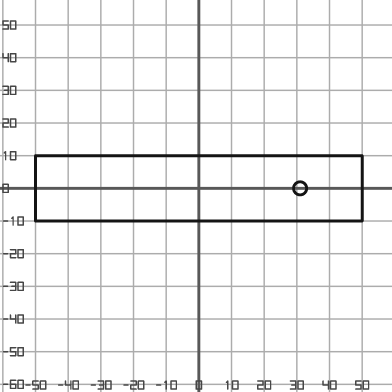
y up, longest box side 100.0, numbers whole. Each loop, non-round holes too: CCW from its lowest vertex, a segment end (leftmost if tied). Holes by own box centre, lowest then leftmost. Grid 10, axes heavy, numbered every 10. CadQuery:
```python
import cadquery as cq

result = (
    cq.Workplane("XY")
    .moveTo(-50.0, -10.0)
    .lineTo(50.0, -10.0)
    .lineTo(50.0, 10.0)
    .lineTo(-50.0, 10.0)
    .close()
    .moveTo(31.0, 0.0)
    .circle(2.0)
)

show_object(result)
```